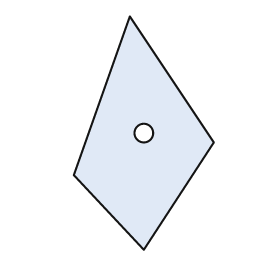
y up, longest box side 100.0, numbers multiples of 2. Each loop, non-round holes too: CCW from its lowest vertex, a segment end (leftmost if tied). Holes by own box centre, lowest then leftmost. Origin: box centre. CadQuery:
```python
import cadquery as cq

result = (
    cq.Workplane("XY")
    .moveTo(0.0, -50.0)
    .lineTo(30.0, -4.0)
    .lineTo(-6.0, 50.0)
    .lineTo(-30.0, -18.0)
    .close()
    .moveTo(0.0, 0.0)
    .circle(4.0)
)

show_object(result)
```